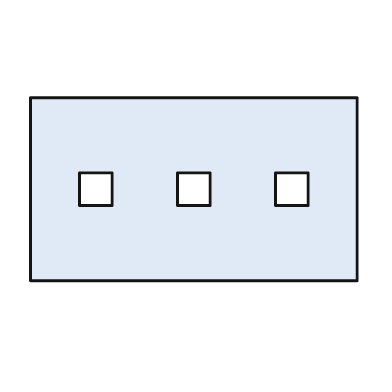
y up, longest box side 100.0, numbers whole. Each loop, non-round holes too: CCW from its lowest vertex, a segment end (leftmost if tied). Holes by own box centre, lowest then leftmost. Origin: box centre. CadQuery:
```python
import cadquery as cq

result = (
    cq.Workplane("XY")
    .moveTo(-50.0, -28.0)
    .lineTo(50.0, -28.0)
    .lineTo(50.0, 28.0)
    .lineTo(-50.0, 28.0)
    .close()
    .moveTo(-35.0, -5.0)
    .lineTo(-25.0, -5.0)
    .lineTo(-25.0, 5.0)
    .lineTo(-35.0, 5.0)
    .close()
    .moveTo(-5.0, -5.0)
    .lineTo(5.0, -5.0)
    .lineTo(5.0, 5.0)
    .lineTo(-5.0, 5.0)
    .close()
    .moveTo(25.0, -5.0)
    .lineTo(35.0, -5.0)
    .lineTo(35.0, 5.0)
    .lineTo(25.0, 5.0)
    .close()
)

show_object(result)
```